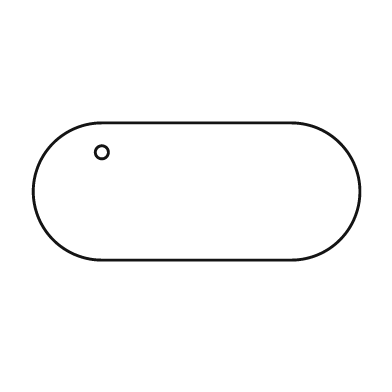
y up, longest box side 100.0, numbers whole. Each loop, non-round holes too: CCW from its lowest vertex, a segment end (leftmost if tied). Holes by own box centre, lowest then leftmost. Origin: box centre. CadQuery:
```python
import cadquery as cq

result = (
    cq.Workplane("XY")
    .moveTo(-29.0, -21.0)
    .lineTo(29.0, -21.0)
    .threePointArc((50.0, 0.0), (29.0, 21.0))
    .lineTo(-29.0, 21.0)
    .threePointArc((-50.0, 0.0), (-29.0, -21.0))
    .close()
    .moveTo(-29.0, 12.0)
    .circle(2.0)
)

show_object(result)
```